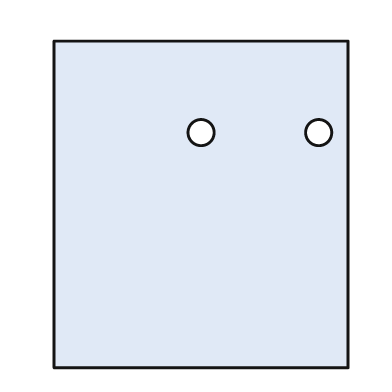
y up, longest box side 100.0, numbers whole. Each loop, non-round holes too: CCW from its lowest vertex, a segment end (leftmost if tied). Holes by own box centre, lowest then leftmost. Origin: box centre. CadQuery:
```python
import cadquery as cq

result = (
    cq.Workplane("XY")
    .moveTo(-45.0, -50.0)
    .lineTo(45.0, -50.0)
    .lineTo(45.0, 50.0)
    .lineTo(-45.0, 50.0)
    .close()
    .moveTo(0.0, 22.0)
    .circle(4.0)
    .moveTo(36.0, 22.0)
    .circle(4.0)
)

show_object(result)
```